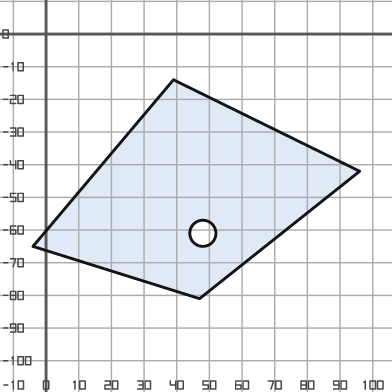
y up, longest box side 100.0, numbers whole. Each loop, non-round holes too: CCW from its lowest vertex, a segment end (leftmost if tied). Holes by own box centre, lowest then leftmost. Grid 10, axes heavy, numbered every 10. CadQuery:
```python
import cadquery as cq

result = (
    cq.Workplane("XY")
    .moveTo(47.0, -81.0)
    .lineTo(96.0, -42.0)
    .lineTo(39.0, -14.0)
    .lineTo(-4.0, -65.0)
    .close()
    .moveTo(48.0, -61.0)
    .circle(4.0)
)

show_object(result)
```